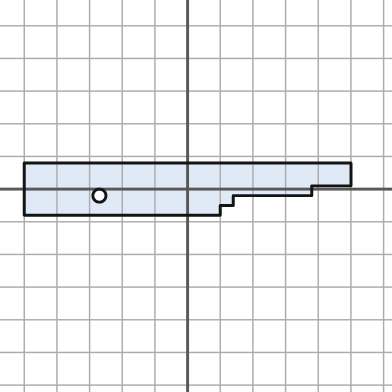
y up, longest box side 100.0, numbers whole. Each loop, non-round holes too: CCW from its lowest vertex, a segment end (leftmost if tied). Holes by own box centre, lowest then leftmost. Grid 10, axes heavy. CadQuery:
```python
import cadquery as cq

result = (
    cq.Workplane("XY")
    .moveTo(-50.0, -8.0)
    .lineTo(10.0, -8.0)
    .lineTo(10.0, -5.0)
    .lineTo(14.0, -5.0)
    .lineTo(14.0, -2.0)
    .lineTo(38.0, -2.0)
    .lineTo(38.0, 1.0)
    .lineTo(50.0, 1.0)
    .lineTo(50.0, 8.0)
    .lineTo(-50.0, 8.0)
    .close()
    .moveTo(-27.0, -2.0)
    .circle(2.0)
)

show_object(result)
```